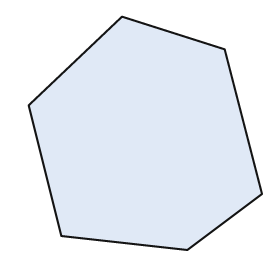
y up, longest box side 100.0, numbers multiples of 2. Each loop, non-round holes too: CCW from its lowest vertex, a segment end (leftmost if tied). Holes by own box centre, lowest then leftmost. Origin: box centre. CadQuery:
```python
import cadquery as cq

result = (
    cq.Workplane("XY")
    .moveTo(18.0, -50.0)
    .lineTo(50.0, -26.0)
    .lineTo(34.0, 36.0)
    .lineTo(-10.0, 50.0)
    .lineTo(-50.0, 12.0)
    .lineTo(-36.0, -44.0)
    .close()
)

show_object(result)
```